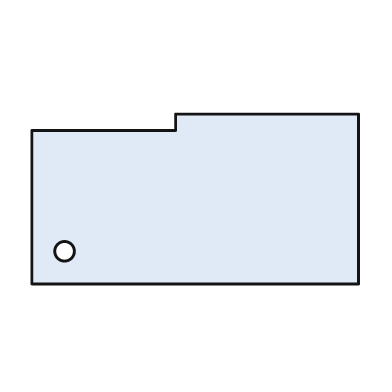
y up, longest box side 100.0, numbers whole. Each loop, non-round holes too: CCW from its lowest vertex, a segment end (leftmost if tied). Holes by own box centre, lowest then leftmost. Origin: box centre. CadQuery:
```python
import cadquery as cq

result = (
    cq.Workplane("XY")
    .moveTo(-50.0, -26.0)
    .lineTo(50.0, -26.0)
    .lineTo(50.0, 26.0)
    .lineTo(-6.0, 26.0)
    .lineTo(-6.0, 21.0)
    .lineTo(-50.0, 21.0)
    .close()
    .moveTo(-40.0, -16.0)
    .circle(3.0)
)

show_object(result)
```